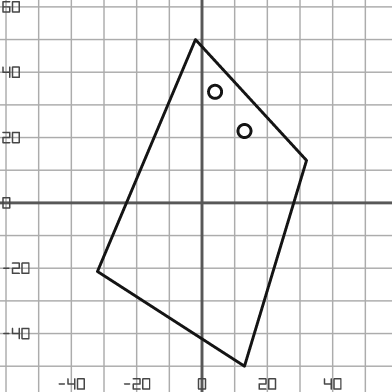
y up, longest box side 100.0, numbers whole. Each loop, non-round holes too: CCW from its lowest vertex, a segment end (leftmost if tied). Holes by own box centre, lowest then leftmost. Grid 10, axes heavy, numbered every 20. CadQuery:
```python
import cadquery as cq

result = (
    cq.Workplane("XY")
    .moveTo(13.0, -50.0)
    .lineTo(32.0, 13.0)
    .lineTo(-2.0, 50.0)
    .lineTo(-32.0, -21.0)
    .close()
    .moveTo(13.0, 22.0)
    .circle(2.0)
    .moveTo(4.0, 34.0)
    .circle(2.0)
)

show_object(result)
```